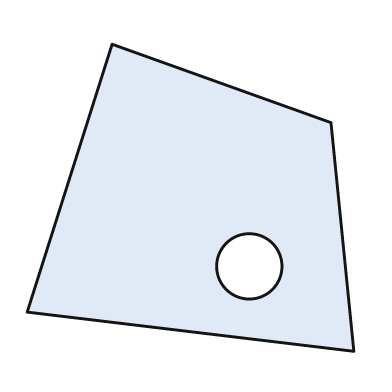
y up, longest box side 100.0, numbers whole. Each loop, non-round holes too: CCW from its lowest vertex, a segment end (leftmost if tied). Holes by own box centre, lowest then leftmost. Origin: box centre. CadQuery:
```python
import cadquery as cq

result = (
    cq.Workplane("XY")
    .moveTo(50.0, -47.0)
    .lineTo(43.0, 23.0)
    .lineTo(-24.0, 47.0)
    .lineTo(-50.0, -35.0)
    .close()
    .moveTo(18.0, -21.0)
    .circle(10.0)
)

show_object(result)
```